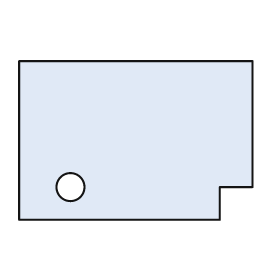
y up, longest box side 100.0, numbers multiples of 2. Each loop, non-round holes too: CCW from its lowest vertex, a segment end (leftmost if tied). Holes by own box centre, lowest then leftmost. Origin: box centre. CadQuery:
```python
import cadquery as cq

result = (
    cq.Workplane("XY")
    .moveTo(-50.0, -34.0)
    .lineTo(36.0, -34.0)
    .lineTo(36.0, -20.0)
    .lineTo(50.0, -20.0)
    .lineTo(50.0, 34.0)
    .lineTo(-50.0, 34.0)
    .close()
    .moveTo(-28.0, -20.0)
    .circle(6.0)
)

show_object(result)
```